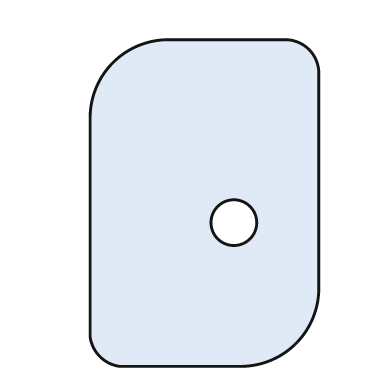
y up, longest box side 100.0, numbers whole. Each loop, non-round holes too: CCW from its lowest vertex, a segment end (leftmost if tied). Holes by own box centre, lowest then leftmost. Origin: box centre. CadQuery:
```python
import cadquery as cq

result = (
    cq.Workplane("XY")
    .moveTo(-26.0, -50.0)
    .lineTo(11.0, -50.0)
    .threePointArc((28.0, -43.0), (35.0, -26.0))
    .lineTo(35.0, 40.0)
    .threePointArc((32.0, 47.0), (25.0, 50.0))
    .lineTo(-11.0, 50.0)
    .threePointArc((-28.0, 43.0), (-35.0, 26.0))
    .lineTo(-35.0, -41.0)
    .threePointArc((-32.0, -47.0), (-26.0, -50.0))
    .close()
    .moveTo(9.0, -6.0)
    .circle(7.0)
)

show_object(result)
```